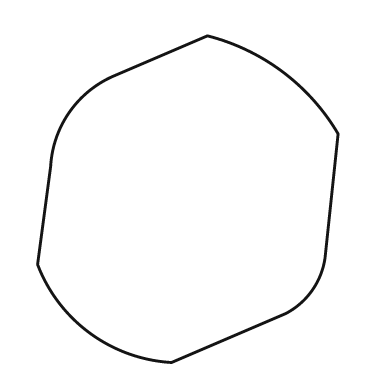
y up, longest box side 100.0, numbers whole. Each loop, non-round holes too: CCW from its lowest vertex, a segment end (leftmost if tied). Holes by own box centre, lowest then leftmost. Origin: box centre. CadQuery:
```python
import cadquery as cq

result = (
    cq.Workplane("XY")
    .moveTo(-5.0, -50.0)
    .lineTo(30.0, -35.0)
    .threePointArc((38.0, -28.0), (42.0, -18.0))
    .lineTo(46.0, 20.0)
    .threePointArc((29.0, 39.0), (6.0, 50.0))
    .lineTo(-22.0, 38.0)
    .threePointArc((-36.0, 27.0), (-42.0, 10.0))
    .lineTo(-46.0, -20.0)
    .threePointArc((-30.0, -41.0), (-5.0, -50.0))
    .close()
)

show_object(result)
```